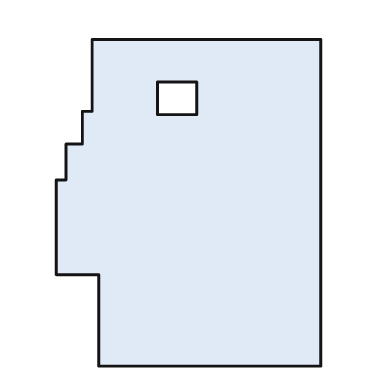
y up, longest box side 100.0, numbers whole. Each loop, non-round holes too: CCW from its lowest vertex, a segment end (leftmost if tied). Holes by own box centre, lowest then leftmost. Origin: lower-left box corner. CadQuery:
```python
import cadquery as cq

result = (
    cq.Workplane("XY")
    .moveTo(13.0, 0.0)
    .lineTo(81.0, 0.0)
    .lineTo(81.0, 100.0)
    .lineTo(11.0, 100.0)
    .lineTo(11.0, 78.0)
    .lineTo(8.0, 78.0)
    .lineTo(8.0, 68.0)
    .lineTo(3.0, 68.0)
    .lineTo(3.0, 57.0)
    .lineTo(0.0, 57.0)
    .lineTo(0.0, 28.0)
    .lineTo(13.0, 28.0)
    .close()
    .moveTo(31.0, 77.0)
    .lineTo(43.0, 77.0)
    .lineTo(43.0, 87.0)
    .lineTo(31.0, 87.0)
    .close()
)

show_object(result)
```